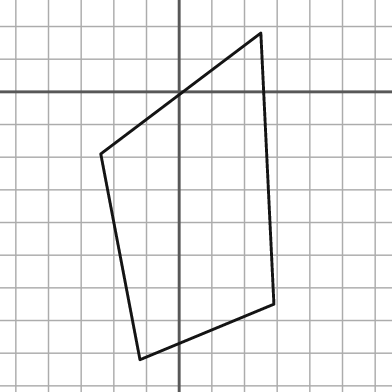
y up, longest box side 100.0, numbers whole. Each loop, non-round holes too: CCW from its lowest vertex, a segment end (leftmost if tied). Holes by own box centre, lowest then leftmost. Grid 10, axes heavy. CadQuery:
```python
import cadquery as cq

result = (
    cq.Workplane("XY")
    .moveTo(-12.0, -82.0)
    .lineTo(29.0, -65.0)
    .lineTo(25.0, 18.0)
    .lineTo(-24.0, -19.0)
    .close()
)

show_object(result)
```